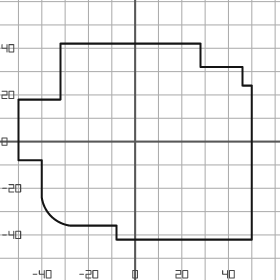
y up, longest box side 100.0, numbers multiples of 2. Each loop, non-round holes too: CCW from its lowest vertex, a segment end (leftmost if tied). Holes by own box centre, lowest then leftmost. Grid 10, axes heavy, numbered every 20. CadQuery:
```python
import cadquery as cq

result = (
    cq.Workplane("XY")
    .moveTo(-8.0, -42.0)
    .lineTo(50.0, -42.0)
    .lineTo(50.0, 24.0)
    .lineTo(46.0, 24.0)
    .lineTo(46.0, 32.0)
    .lineTo(28.0, 32.0)
    .lineTo(28.0, 42.0)
    .lineTo(-32.0, 42.0)
    .lineTo(-32.0, 18.0)
    .lineTo(-50.0, 18.0)
    .lineTo(-50.0, -8.0)
    .lineTo(-40.0, -8.0)
    .lineTo(-40.0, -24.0)
    .threePointArc((-36.0, -32.0), (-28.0, -36.0))
    .lineTo(-8.0, -36.0)
    .close()
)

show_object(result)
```